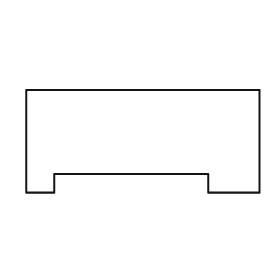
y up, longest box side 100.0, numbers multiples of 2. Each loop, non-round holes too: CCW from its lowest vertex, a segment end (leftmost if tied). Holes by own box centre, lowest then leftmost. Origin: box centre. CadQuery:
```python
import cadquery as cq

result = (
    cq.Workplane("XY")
    .moveTo(-50.0, -22.0)
    .lineTo(-38.0, -22.0)
    .lineTo(-38.0, -14.0)
    .lineTo(28.0, -14.0)
    .lineTo(28.0, -22.0)
    .lineTo(50.0, -22.0)
    .lineTo(50.0, 22.0)
    .lineTo(-50.0, 22.0)
    .close()
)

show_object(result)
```